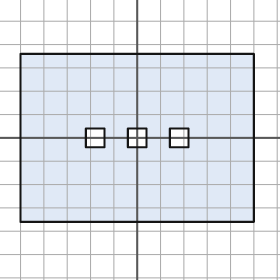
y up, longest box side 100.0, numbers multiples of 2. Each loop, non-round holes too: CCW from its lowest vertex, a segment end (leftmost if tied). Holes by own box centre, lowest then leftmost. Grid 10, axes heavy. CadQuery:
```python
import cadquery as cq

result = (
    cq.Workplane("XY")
    .moveTo(-50.0, -36.0)
    .lineTo(50.0, -36.0)
    .lineTo(50.0, 36.0)
    .lineTo(-50.0, 36.0)
    .close()
    .moveTo(-22.0, -4.0)
    .lineTo(-14.0, -4.0)
    .lineTo(-14.0, 4.0)
    .lineTo(-22.0, 4.0)
    .close()
    .moveTo(-4.0, -4.0)
    .lineTo(4.0, -4.0)
    .lineTo(4.0, 4.0)
    .lineTo(-4.0, 4.0)
    .close()
    .moveTo(14.0, -4.0)
    .lineTo(22.0, -4.0)
    .lineTo(22.0, 4.0)
    .lineTo(14.0, 4.0)
    .close()
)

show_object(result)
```